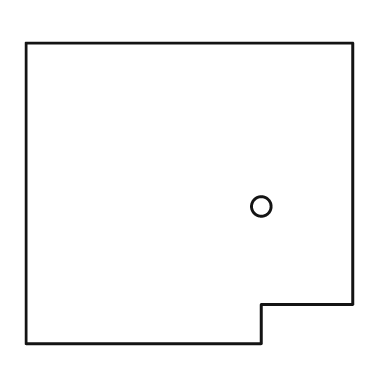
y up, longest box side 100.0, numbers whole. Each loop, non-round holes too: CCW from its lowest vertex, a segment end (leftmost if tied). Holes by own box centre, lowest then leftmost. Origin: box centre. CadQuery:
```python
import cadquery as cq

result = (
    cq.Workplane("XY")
    .moveTo(-50.0, -46.0)
    .lineTo(22.0, -46.0)
    .lineTo(22.0, -34.0)
    .lineTo(50.0, -34.0)
    .lineTo(50.0, 46.0)
    .lineTo(-50.0, 46.0)
    .close()
    .moveTo(22.0, -4.0)
    .circle(3.0)
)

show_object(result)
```